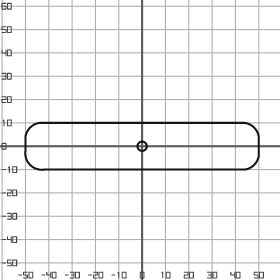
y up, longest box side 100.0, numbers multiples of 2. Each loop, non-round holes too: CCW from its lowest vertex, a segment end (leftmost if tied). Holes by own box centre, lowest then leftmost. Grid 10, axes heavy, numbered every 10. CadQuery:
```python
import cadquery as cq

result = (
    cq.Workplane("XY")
    .moveTo(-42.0, -10.0)
    .lineTo(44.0, -10.0)
    .threePointArc((48.0, -8.0), (50.0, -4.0))
    .lineTo(50.0, 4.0)
    .threePointArc((48.0, 8.0), (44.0, 10.0))
    .lineTo(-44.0, 10.0)
    .threePointArc((-48.0, 8.0), (-50.0, 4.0))
    .lineTo(-50.0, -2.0)
    .threePointArc((-48.0, -8.0), (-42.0, -10.0))
    .close()
    .moveTo(0.0, 0.0)
    .circle(2.0)
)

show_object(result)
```